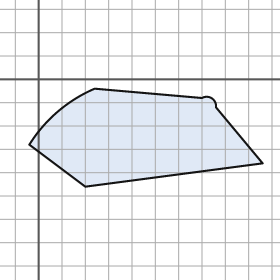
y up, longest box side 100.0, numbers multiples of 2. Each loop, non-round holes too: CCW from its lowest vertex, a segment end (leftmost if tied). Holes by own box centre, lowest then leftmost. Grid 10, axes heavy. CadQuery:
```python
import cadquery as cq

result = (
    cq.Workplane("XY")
    .moveTo(20.0, -46.0)
    .lineTo(96.0, -36.0)
    .lineTo(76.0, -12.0)
    .threePointArc((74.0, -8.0), (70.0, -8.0))
    .lineTo(24.0, -4.0)
    .threePointArc((8.0, -14.0), (-4.0, -28.0))
    .close()
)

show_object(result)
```